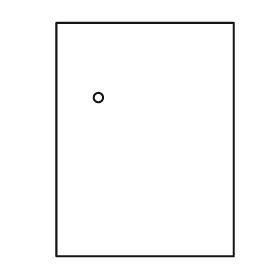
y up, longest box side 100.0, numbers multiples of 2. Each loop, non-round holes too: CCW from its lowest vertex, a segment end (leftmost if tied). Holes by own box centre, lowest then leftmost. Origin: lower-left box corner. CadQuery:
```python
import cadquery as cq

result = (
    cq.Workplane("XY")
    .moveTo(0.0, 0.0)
    .lineTo(76.0, 0.0)
    .lineTo(76.0, 100.0)
    .lineTo(0.0, 100.0)
    .close()
    .moveTo(18.0, 68.0)
    .circle(2.0)
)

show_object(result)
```